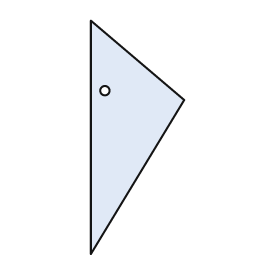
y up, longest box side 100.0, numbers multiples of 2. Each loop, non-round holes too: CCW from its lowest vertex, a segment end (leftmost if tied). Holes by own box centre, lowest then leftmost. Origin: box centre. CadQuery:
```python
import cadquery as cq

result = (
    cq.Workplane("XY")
    .moveTo(-20.0, -50.0)
    .lineTo(20.0, 16.0)
    .lineTo(-20.0, 50.0)
    .close()
    .moveTo(-14.0, 20.0)
    .circle(2.0)
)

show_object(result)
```